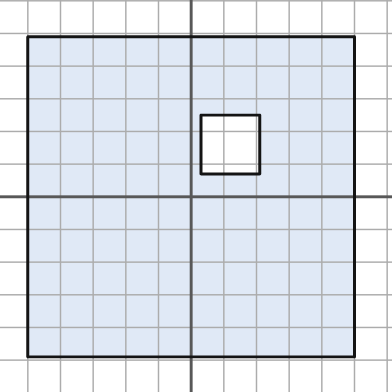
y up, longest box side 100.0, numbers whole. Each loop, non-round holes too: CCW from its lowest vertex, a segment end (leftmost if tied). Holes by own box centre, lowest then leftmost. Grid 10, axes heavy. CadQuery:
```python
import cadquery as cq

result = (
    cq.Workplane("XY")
    .moveTo(-50.0, -49.0)
    .lineTo(50.0, -49.0)
    .lineTo(50.0, 49.0)
    .lineTo(-50.0, 49.0)
    .close()
    .moveTo(3.0, 7.0)
    .lineTo(21.0, 7.0)
    .lineTo(21.0, 25.0)
    .lineTo(3.0, 25.0)
    .close()
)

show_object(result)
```